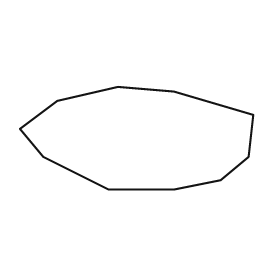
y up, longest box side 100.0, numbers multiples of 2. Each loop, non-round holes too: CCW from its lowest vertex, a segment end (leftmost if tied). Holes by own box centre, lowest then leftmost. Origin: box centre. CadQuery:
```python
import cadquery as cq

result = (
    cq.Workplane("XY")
    .moveTo(-12.0, -22.0)
    .lineTo(16.0, -22.0)
    .lineTo(36.0, -18.0)
    .lineTo(48.0, -8.0)
    .lineTo(50.0, 10.0)
    .lineTo(16.0, 20.0)
    .lineTo(-8.0, 22.0)
    .lineTo(-34.0, 16.0)
    .lineTo(-50.0, 4.0)
    .lineTo(-40.0, -8.0)
    .close()
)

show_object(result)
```